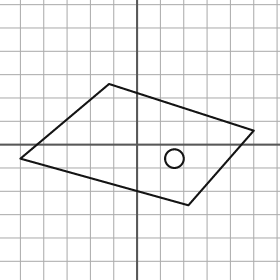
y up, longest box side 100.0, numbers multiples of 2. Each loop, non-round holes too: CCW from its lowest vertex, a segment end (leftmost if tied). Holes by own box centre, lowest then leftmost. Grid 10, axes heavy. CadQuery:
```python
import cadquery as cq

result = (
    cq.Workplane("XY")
    .moveTo(22.0, -26.0)
    .lineTo(50.0, 6.0)
    .lineTo(-12.0, 26.0)
    .lineTo(-50.0, -6.0)
    .close()
    .moveTo(16.0, -6.0)
    .circle(4.0)
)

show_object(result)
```